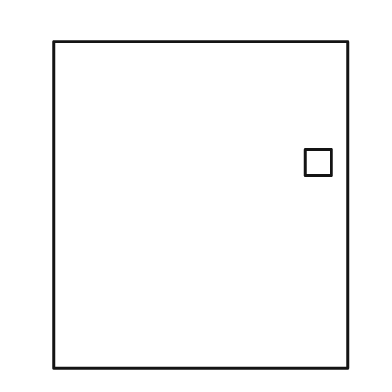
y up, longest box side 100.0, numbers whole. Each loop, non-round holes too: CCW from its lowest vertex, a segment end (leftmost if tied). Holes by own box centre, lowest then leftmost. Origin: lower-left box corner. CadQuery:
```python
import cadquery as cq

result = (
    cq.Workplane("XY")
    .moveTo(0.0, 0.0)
    .lineTo(90.0, 0.0)
    .lineTo(90.0, 100.0)
    .lineTo(0.0, 100.0)
    .close()
    .moveTo(77.0, 59.0)
    .lineTo(85.0, 59.0)
    .lineTo(85.0, 67.0)
    .lineTo(77.0, 67.0)
    .close()
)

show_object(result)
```